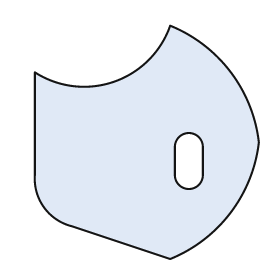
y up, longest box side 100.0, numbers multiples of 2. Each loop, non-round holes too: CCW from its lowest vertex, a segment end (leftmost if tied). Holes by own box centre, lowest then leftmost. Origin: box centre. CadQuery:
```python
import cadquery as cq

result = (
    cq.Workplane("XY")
    .moveTo(10.0, -50.0)
    .threePointArc((36.0, -30.0), (48.0, 0.0))
    .threePointArc((36.0, 30.0), (10.0, 50.0))
    .threePointArc((-14.0, 26.0), (-48.0, 30.0))
    .lineTo(-48.0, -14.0)
    .threePointArc((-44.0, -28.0), (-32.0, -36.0))
    .close()
    .moveTo(12.0, -14.0)
    .threePointArc((18.0, -20.0), (24.0, -14.0))
    .lineTo(24.0, -2.0)
    .threePointArc((18.0, 4.0), (12.0, -2.0))
    .close()
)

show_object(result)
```